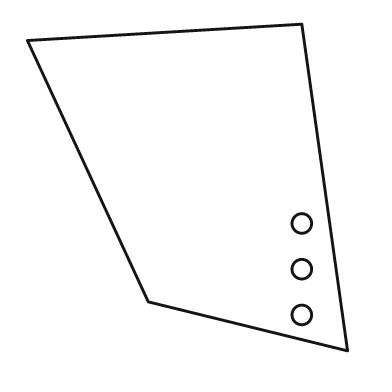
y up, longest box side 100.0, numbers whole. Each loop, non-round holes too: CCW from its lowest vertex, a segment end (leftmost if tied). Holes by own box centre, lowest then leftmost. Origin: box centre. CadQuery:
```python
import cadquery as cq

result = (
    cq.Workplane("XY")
    .moveTo(49.0, -50.0)
    .lineTo(35.0, 50.0)
    .lineTo(-49.0, 45.0)
    .lineTo(-12.0, -35.0)
    .close()
    .moveTo(35.0, -39.0)
    .circle(3.0)
    .moveTo(35.0, -25.0)
    .circle(3.0)
    .moveTo(35.0, -11.0)
    .circle(3.0)
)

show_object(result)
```